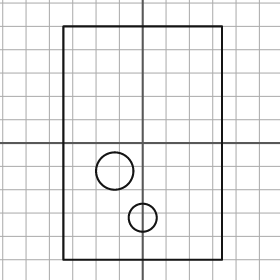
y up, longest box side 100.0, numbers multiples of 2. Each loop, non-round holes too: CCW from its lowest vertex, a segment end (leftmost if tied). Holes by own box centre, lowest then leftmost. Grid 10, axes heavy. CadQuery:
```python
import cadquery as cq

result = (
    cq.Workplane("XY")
    .moveTo(-34.0, -50.0)
    .lineTo(34.0, -50.0)
    .lineTo(34.0, 50.0)
    .lineTo(-34.0, 50.0)
    .close()
    .moveTo(0.0, -32.0)
    .circle(6.0)
    .moveTo(-12.0, -12.0)
    .circle(8.0)
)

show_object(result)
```